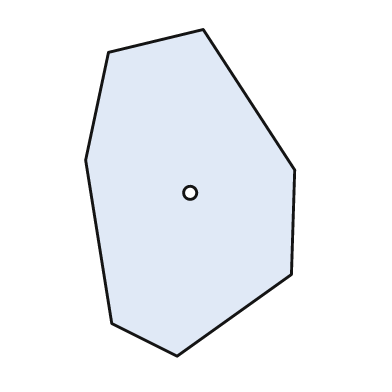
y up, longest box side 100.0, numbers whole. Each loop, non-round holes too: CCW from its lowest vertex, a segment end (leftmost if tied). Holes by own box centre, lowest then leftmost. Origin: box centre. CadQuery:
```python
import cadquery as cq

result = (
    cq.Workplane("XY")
    .moveTo(-4.0, -50.0)
    .lineTo(31.0, -25.0)
    .lineTo(32.0, 7.0)
    .lineTo(4.0, 50.0)
    .lineTo(-25.0, 43.0)
    .lineTo(-32.0, 10.0)
    .lineTo(-24.0, -40.0)
    .close()
    .moveTo(0.0, 0.0)
    .circle(2.0)
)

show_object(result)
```